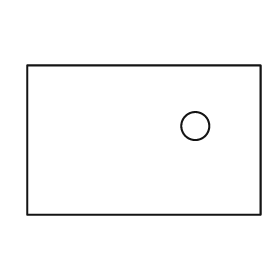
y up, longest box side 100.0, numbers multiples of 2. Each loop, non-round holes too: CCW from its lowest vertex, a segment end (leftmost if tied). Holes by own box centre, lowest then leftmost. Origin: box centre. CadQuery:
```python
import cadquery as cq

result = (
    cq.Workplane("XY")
    .moveTo(-50.0, -32.0)
    .lineTo(50.0, -32.0)
    .lineTo(50.0, 32.0)
    .lineTo(-50.0, 32.0)
    .close()
    .moveTo(22.0, 6.0)
    .circle(6.0)
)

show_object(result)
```